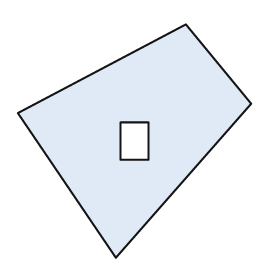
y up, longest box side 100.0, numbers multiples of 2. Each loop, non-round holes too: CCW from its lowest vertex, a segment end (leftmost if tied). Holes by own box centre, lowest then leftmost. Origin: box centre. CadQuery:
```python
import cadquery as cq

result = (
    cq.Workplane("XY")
    .moveTo(-8.0, -50.0)
    .lineTo(50.0, 16.0)
    .lineTo(22.0, 50.0)
    .lineTo(-50.0, 12.0)
    .close()
    .moveTo(-6.0, -8.0)
    .lineTo(6.0, -8.0)
    .lineTo(6.0, 8.0)
    .lineTo(-6.0, 8.0)
    .close()
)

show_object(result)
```